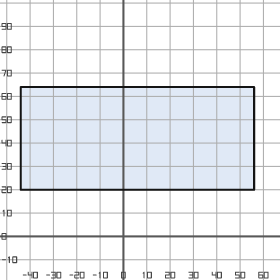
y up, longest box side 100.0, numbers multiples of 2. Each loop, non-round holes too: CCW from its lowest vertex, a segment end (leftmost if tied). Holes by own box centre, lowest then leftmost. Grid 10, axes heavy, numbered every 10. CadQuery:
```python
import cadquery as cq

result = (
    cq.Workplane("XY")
    .moveTo(-44.0, 20.0)
    .lineTo(56.0, 20.0)
    .lineTo(56.0, 64.0)
    .lineTo(-44.0, 64.0)
    .close()
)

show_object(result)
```